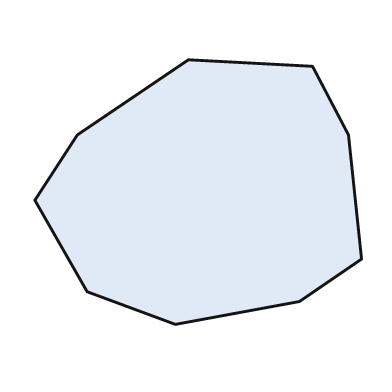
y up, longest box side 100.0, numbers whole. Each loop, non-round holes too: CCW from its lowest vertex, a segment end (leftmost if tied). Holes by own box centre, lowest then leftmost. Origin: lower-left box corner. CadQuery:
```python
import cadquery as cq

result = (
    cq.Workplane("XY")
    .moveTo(43.0, 0.0)
    .lineTo(81.0, 7.0)
    .lineTo(100.0, 20.0)
    .lineTo(96.0, 58.0)
    .lineTo(85.0, 79.0)
    .lineTo(47.0, 81.0)
    .lineTo(13.0, 58.0)
    .lineTo(0.0, 38.0)
    .lineTo(16.0, 10.0)
    .close()
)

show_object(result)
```